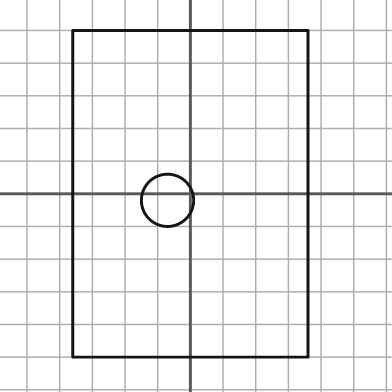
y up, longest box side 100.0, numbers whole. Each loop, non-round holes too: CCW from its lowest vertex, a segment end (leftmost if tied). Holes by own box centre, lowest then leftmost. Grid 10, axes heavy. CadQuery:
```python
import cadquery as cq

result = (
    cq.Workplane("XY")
    .moveTo(-36.0, -50.0)
    .lineTo(36.0, -50.0)
    .lineTo(36.0, 50.0)
    .lineTo(-36.0, 50.0)
    .close()
    .moveTo(-7.0, -2.0)
    .circle(8.0)
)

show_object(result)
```